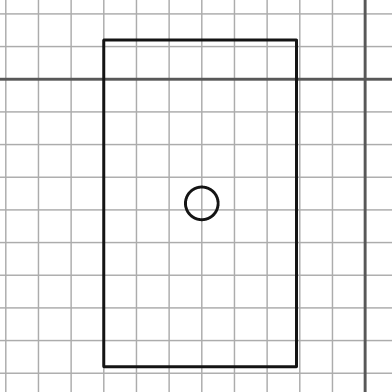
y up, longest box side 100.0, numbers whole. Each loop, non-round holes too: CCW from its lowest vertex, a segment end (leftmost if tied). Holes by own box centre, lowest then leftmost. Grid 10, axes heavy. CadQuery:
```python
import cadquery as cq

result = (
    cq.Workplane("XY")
    .moveTo(-80.0, -88.0)
    .lineTo(-21.0, -88.0)
    .lineTo(-21.0, 12.0)
    .lineTo(-80.0, 12.0)
    .close()
    .moveTo(-50.0, -38.0)
    .circle(5.0)
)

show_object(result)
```